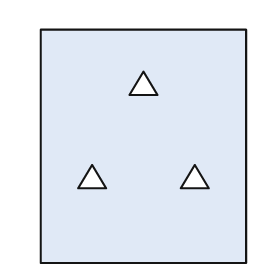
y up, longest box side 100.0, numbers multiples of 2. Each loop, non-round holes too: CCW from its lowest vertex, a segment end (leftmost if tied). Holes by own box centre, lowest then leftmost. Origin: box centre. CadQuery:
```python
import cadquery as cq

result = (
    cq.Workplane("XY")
    .moveTo(-44.0, -50.0)
    .lineTo(44.0, -50.0)
    .lineTo(44.0, 50.0)
    .lineTo(-44.0, 50.0)
    .close()
    .moveTo(-28.0, -18.0)
    .lineTo(-16.0, -18.0)
    .lineTo(-22.0, -8.0)
    .close()
    .moveTo(16.0, -18.0)
    .lineTo(28.0, -18.0)
    .lineTo(22.0, -8.0)
    .close()
    .moveTo(-6.0, 22.0)
    .lineTo(6.0, 22.0)
    .lineTo(0.0, 32.0)
    .close()
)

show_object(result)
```